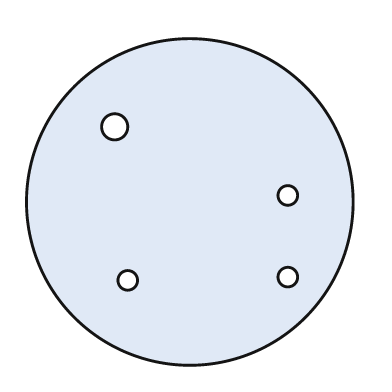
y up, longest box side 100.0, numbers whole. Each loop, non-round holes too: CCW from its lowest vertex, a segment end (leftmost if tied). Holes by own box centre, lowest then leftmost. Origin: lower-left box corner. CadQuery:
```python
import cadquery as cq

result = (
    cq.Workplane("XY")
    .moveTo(50.0, 50.0)
    .circle(50.0)
    .moveTo(31.0, 26.0)
    .circle(3.0)
    .moveTo(80.0, 27.0)
    .circle(3.0)
    .moveTo(80.0, 52.0)
    .circle(3.0)
    .moveTo(27.0, 73.0)
    .circle(4.0)
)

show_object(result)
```